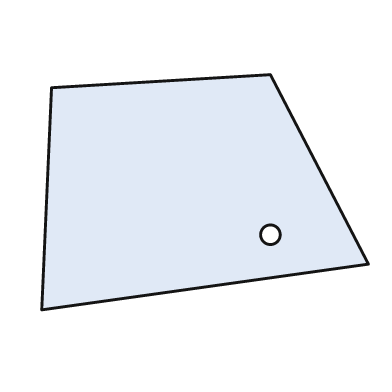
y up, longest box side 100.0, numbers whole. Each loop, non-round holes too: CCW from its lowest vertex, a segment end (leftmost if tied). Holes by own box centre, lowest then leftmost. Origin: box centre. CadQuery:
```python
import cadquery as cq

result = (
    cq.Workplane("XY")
    .moveTo(-50.0, -36.0)
    .lineTo(50.0, -22.0)
    .lineTo(20.0, 36.0)
    .lineTo(-47.0, 32.0)
    .close()
    .moveTo(20.0, -13.0)
    .circle(3.0)
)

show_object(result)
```